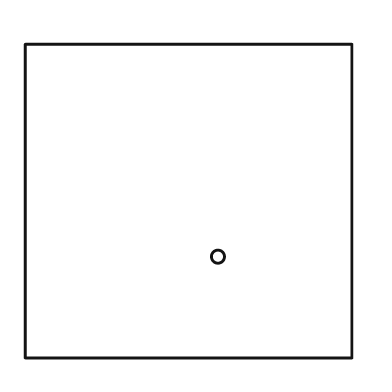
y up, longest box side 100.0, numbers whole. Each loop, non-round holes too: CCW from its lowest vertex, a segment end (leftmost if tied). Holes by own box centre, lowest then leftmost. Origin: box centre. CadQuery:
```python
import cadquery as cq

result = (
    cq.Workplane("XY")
    .moveTo(-50.0, -48.0)
    .lineTo(50.0, -48.0)
    .lineTo(50.0, 48.0)
    .lineTo(-50.0, 48.0)
    .close()
    .moveTo(9.0, -17.0)
    .circle(2.0)
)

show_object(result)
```